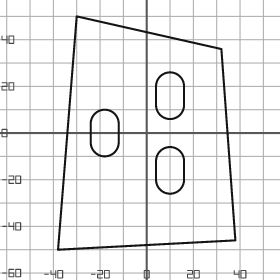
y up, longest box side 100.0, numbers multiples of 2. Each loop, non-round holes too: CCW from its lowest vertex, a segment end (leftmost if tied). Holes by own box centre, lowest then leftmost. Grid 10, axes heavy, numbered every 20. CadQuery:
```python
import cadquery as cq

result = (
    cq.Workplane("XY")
    .moveTo(-38.0, -50.0)
    .lineTo(38.0, -46.0)
    .lineTo(32.0, 36.0)
    .lineTo(-30.0, 50.0)
    .close()
    .moveTo(4.0, -20.0)
    .threePointArc((10.0, -26.0), (16.0, -20.0))
    .lineTo(16.0, -12.0)
    .threePointArc((10.0, -6.0), (4.0, -12.0))
    .close()
    .moveTo(-24.0, -4.0)
    .threePointArc((-18.0, -10.0), (-12.0, -4.0))
    .lineTo(-12.0, 4.0)
    .threePointArc((-18.0, 10.0), (-24.0, 4.0))
    .close()
    .moveTo(4.0, 12.0)
    .threePointArc((10.0, 6.0), (16.0, 12.0))
    .lineTo(16.0, 20.0)
    .threePointArc((10.0, 26.0), (4.0, 20.0))
    .close()
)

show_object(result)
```